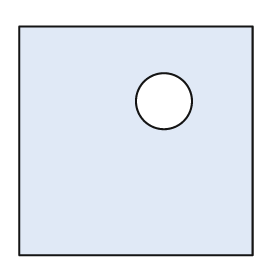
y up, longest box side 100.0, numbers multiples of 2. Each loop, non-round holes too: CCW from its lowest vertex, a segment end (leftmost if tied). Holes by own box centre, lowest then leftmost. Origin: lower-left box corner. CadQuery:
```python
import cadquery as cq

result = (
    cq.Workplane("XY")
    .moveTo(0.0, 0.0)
    .lineTo(100.0, 0.0)
    .lineTo(100.0, 98.0)
    .lineTo(0.0, 98.0)
    .close()
    .moveTo(62.0, 66.0)
    .circle(12.0)
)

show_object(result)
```